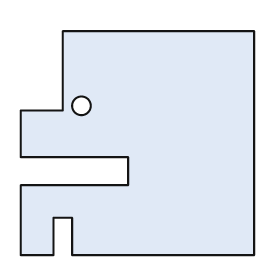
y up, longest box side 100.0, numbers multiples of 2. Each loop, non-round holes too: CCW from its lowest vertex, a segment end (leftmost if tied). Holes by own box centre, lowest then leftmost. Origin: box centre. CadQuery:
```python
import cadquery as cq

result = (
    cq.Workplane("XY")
    .moveTo(-50.0, -48.0)
    .lineTo(-36.0, -48.0)
    .lineTo(-36.0, -32.0)
    .lineTo(-28.0, -32.0)
    .lineTo(-28.0, -48.0)
    .lineTo(50.0, -48.0)
    .lineTo(50.0, 48.0)
    .lineTo(-32.0, 48.0)
    .lineTo(-32.0, 14.0)
    .lineTo(-50.0, 14.0)
    .lineTo(-50.0, -6.0)
    .lineTo(-4.0, -6.0)
    .lineTo(-4.0, -18.0)
    .lineTo(-50.0, -18.0)
    .close()
    .moveTo(-24.0, 16.0)
    .circle(4.0)
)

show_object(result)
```